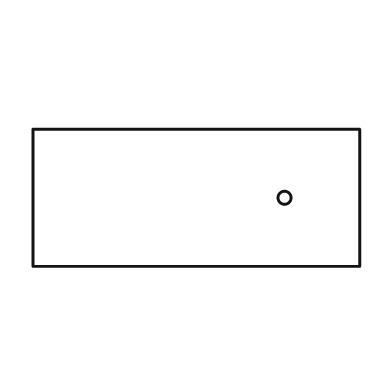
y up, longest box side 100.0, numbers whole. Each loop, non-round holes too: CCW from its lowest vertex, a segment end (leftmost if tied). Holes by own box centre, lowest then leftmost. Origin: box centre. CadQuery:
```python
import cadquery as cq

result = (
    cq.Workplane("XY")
    .moveTo(-50.0, -21.0)
    .lineTo(50.0, -21.0)
    .lineTo(50.0, 21.0)
    .lineTo(-50.0, 21.0)
    .close()
    .moveTo(27.0, 0.0)
    .circle(2.0)
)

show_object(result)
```